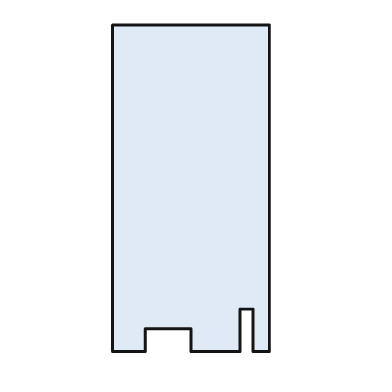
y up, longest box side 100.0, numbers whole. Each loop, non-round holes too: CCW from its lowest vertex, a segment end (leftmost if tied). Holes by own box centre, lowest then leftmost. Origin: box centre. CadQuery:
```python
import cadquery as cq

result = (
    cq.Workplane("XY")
    .moveTo(-24.0, -50.0)
    .lineTo(-14.0, -50.0)
    .lineTo(-14.0, -43.0)
    .lineTo(0.0, -43.0)
    .lineTo(0.0, -50.0)
    .lineTo(15.0, -50.0)
    .lineTo(15.0, -37.0)
    .lineTo(19.0, -37.0)
    .lineTo(19.0, -50.0)
    .lineTo(24.0, -50.0)
    .lineTo(24.0, 50.0)
    .lineTo(-24.0, 50.0)
    .close()
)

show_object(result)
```